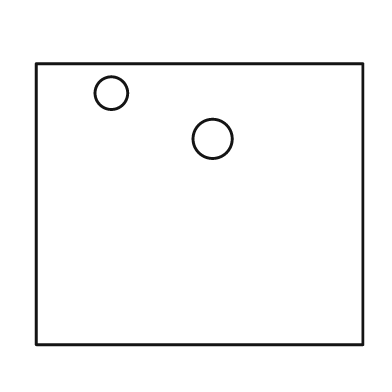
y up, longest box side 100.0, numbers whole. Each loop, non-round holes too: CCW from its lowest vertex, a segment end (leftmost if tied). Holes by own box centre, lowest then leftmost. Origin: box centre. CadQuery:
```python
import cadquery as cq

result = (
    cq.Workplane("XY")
    .moveTo(-50.0, -43.0)
    .lineTo(50.0, -43.0)
    .lineTo(50.0, 43.0)
    .lineTo(-50.0, 43.0)
    .close()
    .moveTo(4.0, 20.0)
    .circle(6.0)
    .moveTo(-27.0, 34.0)
    .circle(5.0)
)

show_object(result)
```